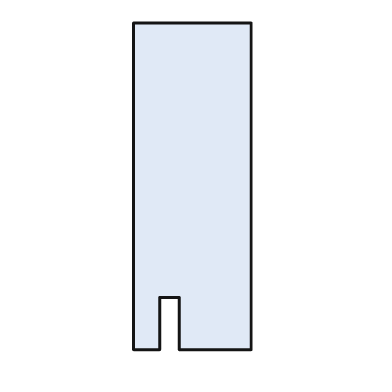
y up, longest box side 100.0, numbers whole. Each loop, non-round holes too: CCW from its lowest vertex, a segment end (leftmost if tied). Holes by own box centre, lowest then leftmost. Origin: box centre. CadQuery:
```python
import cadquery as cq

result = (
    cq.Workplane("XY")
    .moveTo(-18.0, -50.0)
    .lineTo(-10.0, -50.0)
    .lineTo(-10.0, -34.0)
    .lineTo(-4.0, -34.0)
    .lineTo(-4.0, -50.0)
    .lineTo(18.0, -50.0)
    .lineTo(18.0, 50.0)
    .lineTo(-18.0, 50.0)
    .close()
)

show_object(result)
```